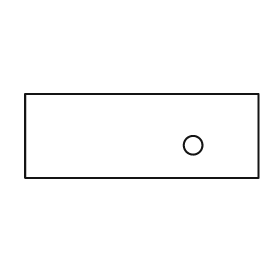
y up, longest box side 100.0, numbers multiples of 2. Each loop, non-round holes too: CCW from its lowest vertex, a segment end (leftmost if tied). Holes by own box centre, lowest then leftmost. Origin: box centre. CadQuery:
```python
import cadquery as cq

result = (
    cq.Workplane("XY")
    .moveTo(-50.0, -18.0)
    .lineTo(50.0, -18.0)
    .lineTo(50.0, 18.0)
    .lineTo(-50.0, 18.0)
    .close()
    .moveTo(22.0, -4.0)
    .circle(4.0)
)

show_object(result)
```